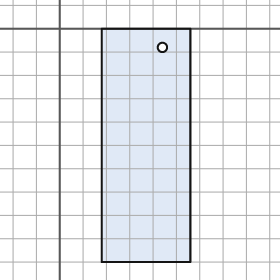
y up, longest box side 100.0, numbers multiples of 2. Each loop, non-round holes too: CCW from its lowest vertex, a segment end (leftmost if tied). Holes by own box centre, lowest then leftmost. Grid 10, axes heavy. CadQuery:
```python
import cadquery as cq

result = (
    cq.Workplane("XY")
    .moveTo(18.0, -100.0)
    .lineTo(56.0, -100.0)
    .lineTo(56.0, 0.0)
    .lineTo(18.0, 0.0)
    .close()
    .moveTo(44.0, -8.0)
    .circle(2.0)
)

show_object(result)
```